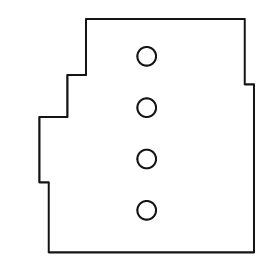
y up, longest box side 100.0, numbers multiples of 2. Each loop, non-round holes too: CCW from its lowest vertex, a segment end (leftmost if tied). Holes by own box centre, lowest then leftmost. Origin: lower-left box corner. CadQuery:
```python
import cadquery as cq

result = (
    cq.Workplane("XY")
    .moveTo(4.0, 0.0)
    .lineTo(92.0, 0.0)
    .lineTo(92.0, 72.0)
    .lineTo(88.0, 72.0)
    .lineTo(88.0, 100.0)
    .lineTo(20.0, 100.0)
    .lineTo(20.0, 76.0)
    .lineTo(12.0, 76.0)
    .lineTo(12.0, 58.0)
    .lineTo(0.0, 58.0)
    .lineTo(0.0, 30.0)
    .lineTo(4.0, 30.0)
    .close()
    .moveTo(46.0, 18.0)
    .circle(4.0)
    .moveTo(46.0, 40.0)
    .circle(4.0)
    .moveTo(46.0, 62.0)
    .circle(4.0)
    .moveTo(46.0, 84.0)
    .circle(4.0)
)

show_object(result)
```